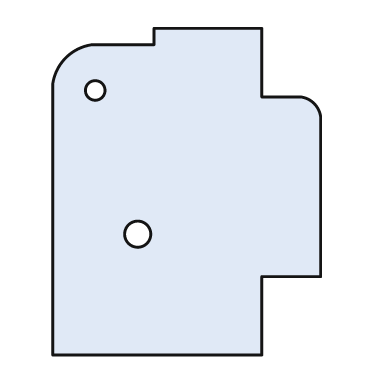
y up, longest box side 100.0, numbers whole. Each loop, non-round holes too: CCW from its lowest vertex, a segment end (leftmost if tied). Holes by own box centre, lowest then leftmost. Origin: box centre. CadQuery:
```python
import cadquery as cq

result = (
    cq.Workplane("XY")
    .moveTo(-41.0, -50.0)
    .lineTo(23.0, -50.0)
    .lineTo(23.0, -26.0)
    .lineTo(41.0, -26.0)
    .lineTo(41.0, 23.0)
    .threePointArc((39.0, 27.0), (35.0, 29.0))
    .lineTo(23.0, 29.0)
    .lineTo(23.0, 50.0)
    .lineTo(-10.0, 50.0)
    .lineTo(-10.0, 45.0)
    .lineTo(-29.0, 45.0)
    .threePointArc((-37.0, 41.0), (-41.0, 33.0))
    .close()
    .moveTo(-15.0, -13.0)
    .circle(4.0)
    .moveTo(-28.0, 31.0)
    .circle(3.0)
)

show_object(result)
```